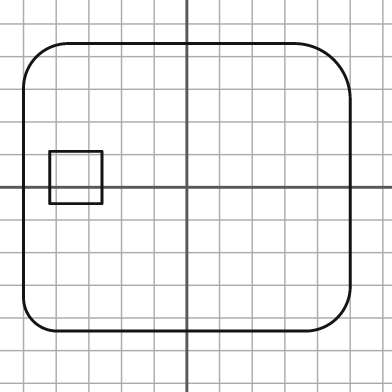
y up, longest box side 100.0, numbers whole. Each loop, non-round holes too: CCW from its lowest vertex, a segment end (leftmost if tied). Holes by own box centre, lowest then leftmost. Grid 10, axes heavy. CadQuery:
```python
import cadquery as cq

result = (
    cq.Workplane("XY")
    .moveTo(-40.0, -44.0)
    .lineTo(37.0, -44.0)
    .threePointArc((46.0, -40.0), (50.0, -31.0))
    .lineTo(50.0, 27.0)
    .threePointArc((45.0, 39.0), (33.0, 44.0))
    .lineTo(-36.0, 44.0)
    .threePointArc((-46.0, 40.0), (-50.0, 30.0))
    .lineTo(-50.0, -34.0)
    .threePointArc((-47.0, -41.0), (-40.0, -44.0))
    .close()
    .moveTo(-42.0, -5.0)
    .lineTo(-26.0, -5.0)
    .lineTo(-26.0, 11.0)
    .lineTo(-42.0, 11.0)
    .close()
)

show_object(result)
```